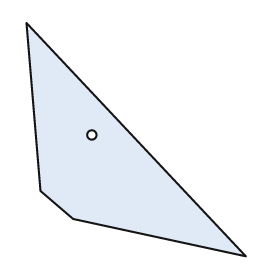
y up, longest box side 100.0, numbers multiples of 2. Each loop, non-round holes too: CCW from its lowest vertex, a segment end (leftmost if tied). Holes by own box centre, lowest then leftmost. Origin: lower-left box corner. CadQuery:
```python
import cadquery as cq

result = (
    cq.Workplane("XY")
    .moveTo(94.0, 0.0)
    .lineTo(0.0, 100.0)
    .lineTo(6.0, 28.0)
    .lineTo(20.0, 16.0)
    .close()
    .moveTo(28.0, 52.0)
    .circle(2.0)
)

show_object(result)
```